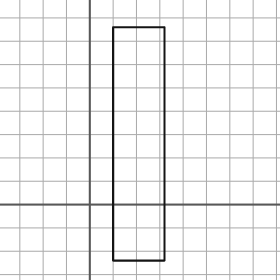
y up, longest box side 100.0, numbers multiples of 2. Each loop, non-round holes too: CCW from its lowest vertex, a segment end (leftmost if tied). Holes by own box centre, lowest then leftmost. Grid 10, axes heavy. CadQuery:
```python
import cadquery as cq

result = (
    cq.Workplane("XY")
    .moveTo(10.0, -24.0)
    .lineTo(32.0, -24.0)
    .lineTo(32.0, 76.0)
    .lineTo(10.0, 76.0)
    .close()
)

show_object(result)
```